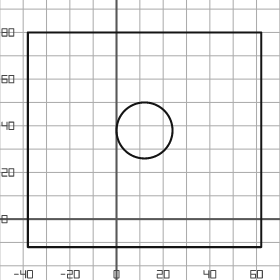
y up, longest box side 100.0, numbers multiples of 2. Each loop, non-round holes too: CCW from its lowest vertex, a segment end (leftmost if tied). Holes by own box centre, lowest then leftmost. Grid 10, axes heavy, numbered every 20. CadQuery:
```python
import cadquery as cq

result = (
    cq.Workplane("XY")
    .moveTo(-38.0, -12.0)
    .lineTo(62.0, -12.0)
    .lineTo(62.0, 80.0)
    .lineTo(-38.0, 80.0)
    .close()
    .moveTo(12.0, 38.0)
    .circle(12.0)
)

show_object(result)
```